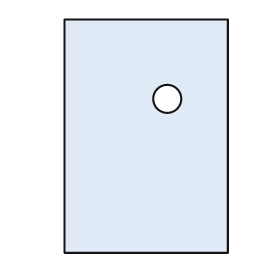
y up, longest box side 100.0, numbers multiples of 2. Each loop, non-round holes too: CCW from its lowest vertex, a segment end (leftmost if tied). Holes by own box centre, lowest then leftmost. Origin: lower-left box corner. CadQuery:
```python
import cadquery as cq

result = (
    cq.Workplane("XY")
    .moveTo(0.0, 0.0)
    .lineTo(70.0, 0.0)
    .lineTo(70.0, 100.0)
    .lineTo(0.0, 100.0)
    .close()
    .moveTo(44.0, 66.0)
    .circle(6.0)
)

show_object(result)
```